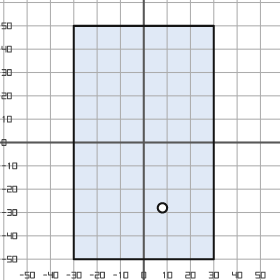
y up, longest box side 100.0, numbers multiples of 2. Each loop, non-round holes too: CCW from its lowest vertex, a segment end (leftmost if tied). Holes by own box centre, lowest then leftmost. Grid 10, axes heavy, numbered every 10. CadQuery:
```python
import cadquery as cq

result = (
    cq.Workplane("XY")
    .moveTo(-30.0, -50.0)
    .lineTo(30.0, -50.0)
    .lineTo(30.0, 50.0)
    .lineTo(-30.0, 50.0)
    .close()
    .moveTo(8.0, -28.0)
    .circle(2.0)
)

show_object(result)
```